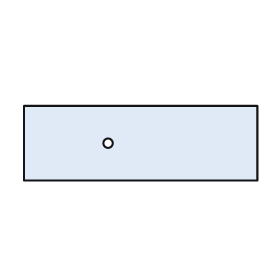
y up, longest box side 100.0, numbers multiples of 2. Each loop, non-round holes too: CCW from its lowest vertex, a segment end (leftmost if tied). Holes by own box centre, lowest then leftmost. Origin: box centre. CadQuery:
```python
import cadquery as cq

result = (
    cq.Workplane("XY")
    .moveTo(-50.0, -16.0)
    .lineTo(50.0, -16.0)
    .lineTo(50.0, 16.0)
    .lineTo(-50.0, 16.0)
    .close()
    .moveTo(-14.0, 0.0)
    .circle(2.0)
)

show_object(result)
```